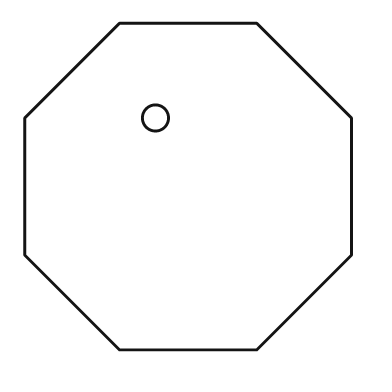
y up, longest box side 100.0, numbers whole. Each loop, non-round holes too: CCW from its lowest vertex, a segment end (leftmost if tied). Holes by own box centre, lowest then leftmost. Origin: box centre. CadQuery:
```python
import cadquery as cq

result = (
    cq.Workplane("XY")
    .moveTo(-21.0, -50.0)
    .lineTo(21.0, -50.0)
    .lineTo(50.0, -21.0)
    .lineTo(50.0, 21.0)
    .lineTo(21.0, 50.0)
    .lineTo(-21.0, 50.0)
    .lineTo(-50.0, 21.0)
    .lineTo(-50.0, -21.0)
    .close()
    .moveTo(-10.0, 21.0)
    .circle(4.0)
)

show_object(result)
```